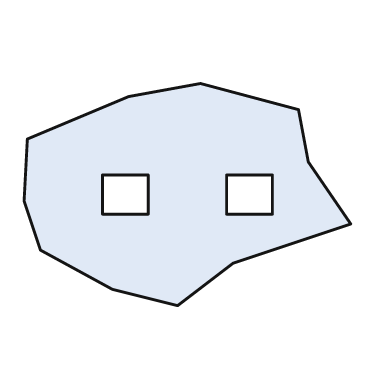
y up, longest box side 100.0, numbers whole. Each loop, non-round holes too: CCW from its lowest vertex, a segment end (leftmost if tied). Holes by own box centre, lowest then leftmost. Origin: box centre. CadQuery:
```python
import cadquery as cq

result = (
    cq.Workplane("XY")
    .moveTo(-3.0, -34.0)
    .lineTo(14.0, -21.0)
    .lineTo(50.0, -9.0)
    .lineTo(37.0, 10.0)
    .lineTo(34.0, 26.0)
    .lineTo(4.0, 34.0)
    .lineTo(-18.0, 30.0)
    .lineTo(-49.0, 17.0)
    .lineTo(-50.0, -2.0)
    .lineTo(-45.0, -17.0)
    .lineTo(-23.0, -29.0)
    .close()
    .moveTo(-26.0, -6.0)
    .lineTo(-12.0, -6.0)
    .lineTo(-12.0, 6.0)
    .lineTo(-26.0, 6.0)
    .close()
    .moveTo(12.0, -6.0)
    .lineTo(26.0, -6.0)
    .lineTo(26.0, 6.0)
    .lineTo(12.0, 6.0)
    .close()
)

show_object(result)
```